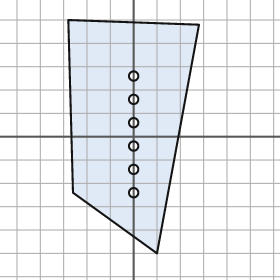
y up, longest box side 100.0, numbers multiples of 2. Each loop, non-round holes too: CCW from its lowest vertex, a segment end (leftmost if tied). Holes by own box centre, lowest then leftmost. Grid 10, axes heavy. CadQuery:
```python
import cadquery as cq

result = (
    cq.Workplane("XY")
    .moveTo(10.0, -50.0)
    .lineTo(28.0, 48.0)
    .lineTo(-28.0, 50.0)
    .lineTo(-26.0, -24.0)
    .close()
    .moveTo(0.0, -24.0)
    .circle(2.0)
    .moveTo(0.0, -14.0)
    .circle(2.0)
    .moveTo(0.0, -4.0)
    .circle(2.0)
    .moveTo(0.0, 6.0)
    .circle(2.0)
    .moveTo(0.0, 16.0)
    .circle(2.0)
    .moveTo(0.0, 26.0)
    .circle(2.0)
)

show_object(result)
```